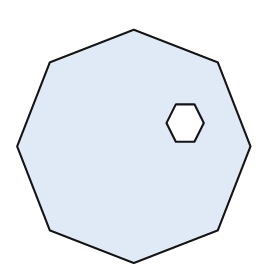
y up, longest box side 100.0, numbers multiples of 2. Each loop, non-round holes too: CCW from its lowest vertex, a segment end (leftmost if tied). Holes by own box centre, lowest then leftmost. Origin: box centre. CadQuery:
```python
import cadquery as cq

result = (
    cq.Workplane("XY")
    .moveTo(0.0, -50.0)
    .lineTo(36.0, -36.0)
    .lineTo(50.0, 0.0)
    .lineTo(36.0, 36.0)
    .lineTo(0.0, 50.0)
    .lineTo(-36.0, 36.0)
    .lineTo(-50.0, 0.0)
    .lineTo(-36.0, -36.0)
    .close()
    .moveTo(18.0, 2.0)
    .lineTo(26.0, 2.0)
    .lineTo(30.0, 10.0)
    .lineTo(26.0, 18.0)
    .lineTo(18.0, 18.0)
    .lineTo(14.0, 10.0)
    .close()
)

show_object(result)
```